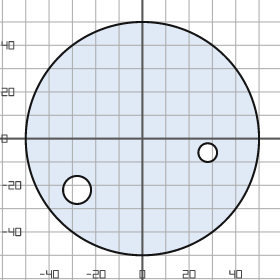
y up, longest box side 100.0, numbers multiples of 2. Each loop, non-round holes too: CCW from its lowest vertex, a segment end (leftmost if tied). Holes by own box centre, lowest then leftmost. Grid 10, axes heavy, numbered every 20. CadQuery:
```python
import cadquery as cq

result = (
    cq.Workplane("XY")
    .moveTo(0.0, 0.0)
    .circle(50.0)
    .moveTo(-28.0, -22.0)
    .circle(6.0)
    .moveTo(28.0, -6.0)
    .circle(4.0)
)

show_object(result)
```